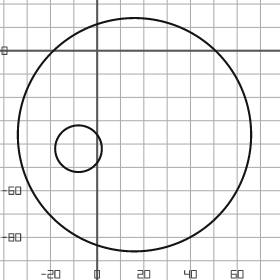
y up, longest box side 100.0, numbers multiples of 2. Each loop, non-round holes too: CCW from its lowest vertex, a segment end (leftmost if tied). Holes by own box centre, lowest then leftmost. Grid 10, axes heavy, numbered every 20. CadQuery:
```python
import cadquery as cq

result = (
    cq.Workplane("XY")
    .moveTo(16.0, -36.0)
    .circle(50.0)
    .moveTo(-8.0, -42.0)
    .circle(10.0)
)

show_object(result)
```